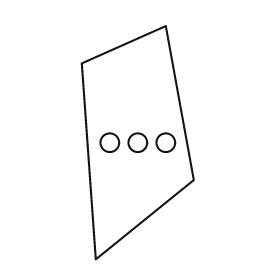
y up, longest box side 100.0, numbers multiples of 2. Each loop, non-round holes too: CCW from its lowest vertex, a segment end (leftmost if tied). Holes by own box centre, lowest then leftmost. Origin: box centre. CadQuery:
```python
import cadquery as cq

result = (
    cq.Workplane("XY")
    .moveTo(-18.0, -50.0)
    .lineTo(24.0, -16.0)
    .lineTo(12.0, 50.0)
    .lineTo(-24.0, 34.0)
    .close()
    .moveTo(-12.0, 0.0)
    .circle(4.0)
    .moveTo(0.0, 0.0)
    .circle(4.0)
    .moveTo(12.0, 0.0)
    .circle(4.0)
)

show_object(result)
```